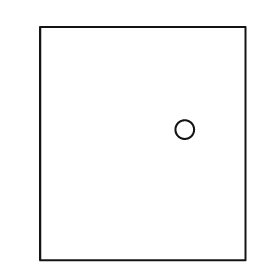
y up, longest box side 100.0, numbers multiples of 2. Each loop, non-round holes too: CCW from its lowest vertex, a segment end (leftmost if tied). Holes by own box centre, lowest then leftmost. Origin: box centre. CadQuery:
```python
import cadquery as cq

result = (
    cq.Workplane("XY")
    .moveTo(-44.0, -50.0)
    .lineTo(44.0, -50.0)
    .lineTo(44.0, 50.0)
    .lineTo(-44.0, 50.0)
    .close()
    .moveTo(18.0, 6.0)
    .circle(4.0)
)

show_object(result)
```